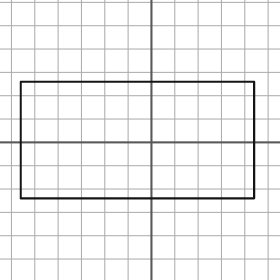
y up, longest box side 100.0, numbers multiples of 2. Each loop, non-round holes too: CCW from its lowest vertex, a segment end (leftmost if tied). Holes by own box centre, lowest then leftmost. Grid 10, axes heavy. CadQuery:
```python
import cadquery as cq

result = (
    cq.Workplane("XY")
    .moveTo(-56.0, -24.0)
    .lineTo(44.0, -24.0)
    .lineTo(44.0, 26.0)
    .lineTo(-56.0, 26.0)
    .close()
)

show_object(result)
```